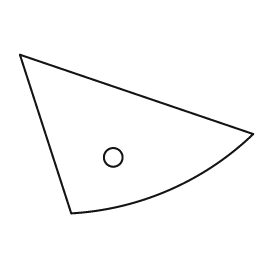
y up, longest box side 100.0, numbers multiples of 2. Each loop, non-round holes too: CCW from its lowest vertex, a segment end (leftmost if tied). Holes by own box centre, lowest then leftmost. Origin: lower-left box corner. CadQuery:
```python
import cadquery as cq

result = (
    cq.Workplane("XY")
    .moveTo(22.0, 0.0)
    .threePointArc((64.0, 10.0), (100.0, 34.0))
    .lineTo(0.0, 68.0)
    .close()
    .moveTo(40.0, 24.0)
    .circle(4.0)
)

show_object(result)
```